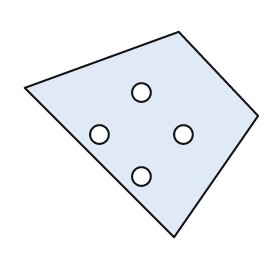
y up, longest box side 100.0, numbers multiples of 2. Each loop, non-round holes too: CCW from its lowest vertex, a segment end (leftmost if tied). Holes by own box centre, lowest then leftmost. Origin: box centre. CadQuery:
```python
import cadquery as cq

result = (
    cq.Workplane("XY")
    .moveTo(14.0, -44.0)
    .lineTo(50.0, 8.0)
    .lineTo(16.0, 44.0)
    .lineTo(-50.0, 20.0)
    .close()
    .moveTo(0.0, -18.0)
    .circle(4.0)
    .moveTo(-18.0, 0.0)
    .circle(4.0)
    .moveTo(18.0, 0.0)
    .circle(4.0)
    .moveTo(0.0, 18.0)
    .circle(4.0)
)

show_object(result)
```